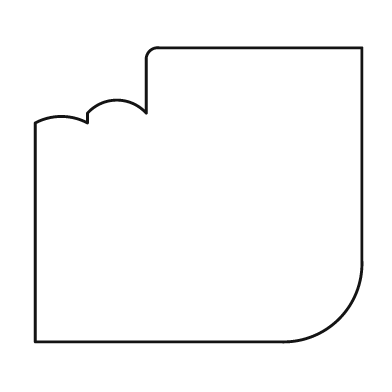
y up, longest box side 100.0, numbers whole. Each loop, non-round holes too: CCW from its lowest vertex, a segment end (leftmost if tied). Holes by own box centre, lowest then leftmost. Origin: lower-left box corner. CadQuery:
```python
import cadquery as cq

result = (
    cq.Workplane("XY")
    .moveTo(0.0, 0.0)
    .lineTo(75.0, 0.0)
    .threePointArc((93.0, 7.0), (100.0, 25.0))
    .lineTo(100.0, 90.0)
    .lineTo(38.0, 90.0)
    .threePointArc((35.0, 89.0), (34.0, 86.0))
    .lineTo(34.0, 70.0)
    .threePointArc((25.0, 74.0), (16.0, 70.0))
    .lineTo(16.0, 67.0)
    .threePointArc((8.0, 69.0), (0.0, 67.0))
    .close()
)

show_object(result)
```